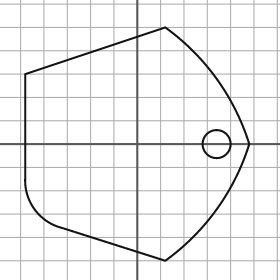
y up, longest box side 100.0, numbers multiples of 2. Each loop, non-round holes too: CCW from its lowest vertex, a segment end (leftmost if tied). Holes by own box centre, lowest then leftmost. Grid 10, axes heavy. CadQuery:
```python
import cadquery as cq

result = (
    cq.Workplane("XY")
    .moveTo(12.0, -50.0)
    .threePointArc((34.0, -28.0), (48.0, 0.0))
    .threePointArc((34.0, 28.0), (12.0, 50.0))
    .lineTo(-48.0, 30.0)
    .lineTo(-48.0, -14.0)
    .threePointArc((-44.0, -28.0), (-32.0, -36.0))
    .close()
    .moveTo(34.0, 0.0)
    .circle(6.0)
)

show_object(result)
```